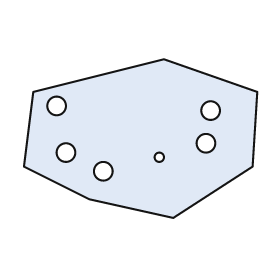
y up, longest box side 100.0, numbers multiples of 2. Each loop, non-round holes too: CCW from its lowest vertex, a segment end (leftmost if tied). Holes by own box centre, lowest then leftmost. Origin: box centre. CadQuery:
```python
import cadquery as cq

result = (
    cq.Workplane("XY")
    .moveTo(14.0, -34.0)
    .lineTo(48.0, -12.0)
    .lineTo(50.0, 20.0)
    .lineTo(10.0, 34.0)
    .lineTo(-46.0, 20.0)
    .lineTo(-50.0, -12.0)
    .lineTo(-22.0, -26.0)
    .close()
    .moveTo(-16.0, -14.0)
    .circle(4.0)
    .moveTo(8.0, -8.0)
    .circle(2.0)
    .moveTo(-32.0, -6.0)
    .circle(4.0)
    .moveTo(28.0, -2.0)
    .circle(4.0)
    .moveTo(30.0, 12.0)
    .circle(4.0)
    .moveTo(-36.0, 14.0)
    .circle(4.0)
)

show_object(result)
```